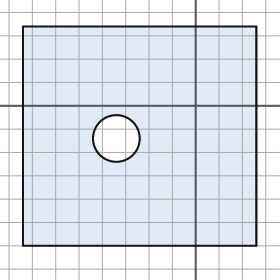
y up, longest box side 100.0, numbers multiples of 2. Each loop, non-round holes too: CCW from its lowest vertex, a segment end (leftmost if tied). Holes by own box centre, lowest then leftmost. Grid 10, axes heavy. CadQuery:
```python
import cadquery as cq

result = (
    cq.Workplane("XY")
    .moveTo(-74.0, -60.0)
    .lineTo(26.0, -60.0)
    .lineTo(26.0, 34.0)
    .lineTo(-74.0, 34.0)
    .close()
    .moveTo(-34.0, -14.0)
    .circle(10.0)
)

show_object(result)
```